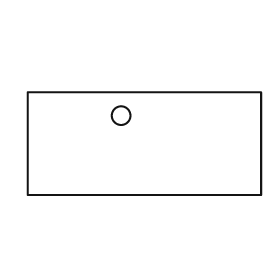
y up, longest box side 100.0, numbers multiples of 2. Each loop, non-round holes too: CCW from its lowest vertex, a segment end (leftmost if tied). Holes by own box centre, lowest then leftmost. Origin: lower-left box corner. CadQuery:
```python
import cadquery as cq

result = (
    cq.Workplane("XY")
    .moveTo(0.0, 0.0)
    .lineTo(100.0, 0.0)
    .lineTo(100.0, 44.0)
    .lineTo(0.0, 44.0)
    .close()
    .moveTo(40.0, 34.0)
    .circle(4.0)
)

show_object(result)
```